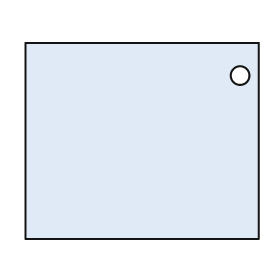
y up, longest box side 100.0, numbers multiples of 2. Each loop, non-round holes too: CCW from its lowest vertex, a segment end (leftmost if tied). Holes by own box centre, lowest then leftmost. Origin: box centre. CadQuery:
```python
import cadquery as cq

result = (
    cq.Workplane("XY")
    .moveTo(-50.0, -42.0)
    .lineTo(50.0, -42.0)
    .lineTo(50.0, 42.0)
    .lineTo(-50.0, 42.0)
    .close()
    .moveTo(42.0, 28.0)
    .circle(4.0)
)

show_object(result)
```